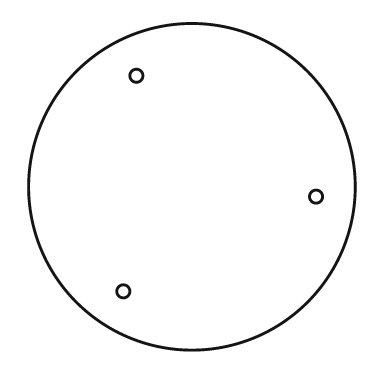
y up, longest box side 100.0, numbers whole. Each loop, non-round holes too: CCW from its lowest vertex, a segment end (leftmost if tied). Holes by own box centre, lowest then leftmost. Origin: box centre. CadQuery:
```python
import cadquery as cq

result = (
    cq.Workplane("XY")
    .moveTo(0.0, 0.0)
    .circle(50.0)
    .moveTo(-21.0, -32.0)
    .circle(2.0)
    .moveTo(38.0, -3.0)
    .circle(2.0)
    .moveTo(-17.0, 34.0)
    .circle(2.0)
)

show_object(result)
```